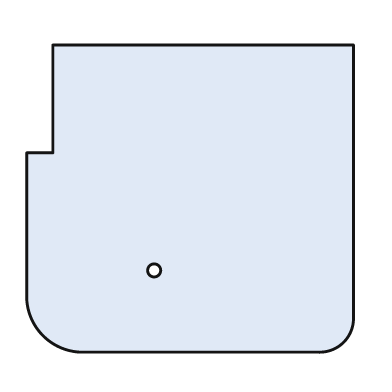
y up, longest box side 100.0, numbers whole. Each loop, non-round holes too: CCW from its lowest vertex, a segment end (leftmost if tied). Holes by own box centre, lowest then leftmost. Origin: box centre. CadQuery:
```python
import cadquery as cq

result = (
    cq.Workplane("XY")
    .moveTo(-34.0, -47.0)
    .lineTo(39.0, -47.0)
    .threePointArc((47.0, -44.0), (50.0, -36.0))
    .lineTo(50.0, 47.0)
    .lineTo(-42.0, 47.0)
    .lineTo(-42.0, 14.0)
    .lineTo(-50.0, 14.0)
    .lineTo(-50.0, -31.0)
    .threePointArc((-45.0, -42.0), (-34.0, -47.0))
    .close()
    .moveTo(-11.0, -22.0)
    .circle(2.0)
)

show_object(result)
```